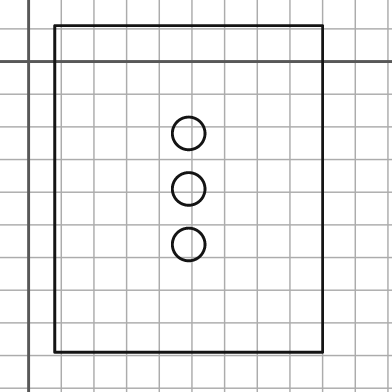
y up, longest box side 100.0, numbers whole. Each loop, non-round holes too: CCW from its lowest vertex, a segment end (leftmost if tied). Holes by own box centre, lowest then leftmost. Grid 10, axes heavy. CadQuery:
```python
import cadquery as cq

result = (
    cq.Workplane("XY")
    .moveTo(8.0, -89.0)
    .lineTo(90.0, -89.0)
    .lineTo(90.0, 11.0)
    .lineTo(8.0, 11.0)
    .close()
    .moveTo(49.0, -56.0)
    .circle(5.0)
    .moveTo(49.0, -39.0)
    .circle(5.0)
    .moveTo(49.0, -22.0)
    .circle(5.0)
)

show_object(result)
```